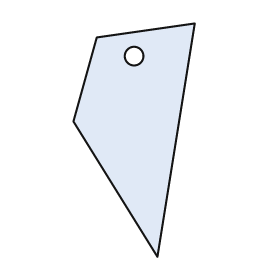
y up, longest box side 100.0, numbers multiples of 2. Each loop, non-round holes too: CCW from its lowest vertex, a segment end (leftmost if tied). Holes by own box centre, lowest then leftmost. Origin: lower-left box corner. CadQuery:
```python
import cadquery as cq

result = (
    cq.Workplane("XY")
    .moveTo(36.0, 0.0)
    .lineTo(52.0, 100.0)
    .lineTo(10.0, 94.0)
    .lineTo(0.0, 58.0)
    .close()
    .moveTo(26.0, 86.0)
    .circle(4.0)
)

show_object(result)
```